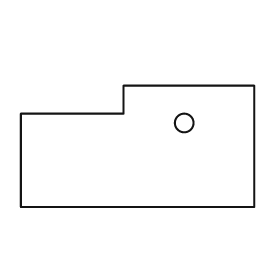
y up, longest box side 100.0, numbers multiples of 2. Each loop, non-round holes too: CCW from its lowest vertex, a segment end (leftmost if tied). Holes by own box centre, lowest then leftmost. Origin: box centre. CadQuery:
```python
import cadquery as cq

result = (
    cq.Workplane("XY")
    .moveTo(-50.0, -26.0)
    .lineTo(50.0, -26.0)
    .lineTo(50.0, 26.0)
    .lineTo(-6.0, 26.0)
    .lineTo(-6.0, 14.0)
    .lineTo(-50.0, 14.0)
    .close()
    .moveTo(20.0, 10.0)
    .circle(4.0)
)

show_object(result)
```